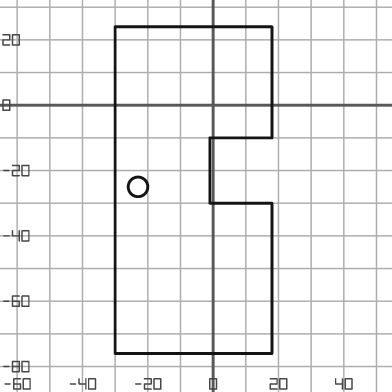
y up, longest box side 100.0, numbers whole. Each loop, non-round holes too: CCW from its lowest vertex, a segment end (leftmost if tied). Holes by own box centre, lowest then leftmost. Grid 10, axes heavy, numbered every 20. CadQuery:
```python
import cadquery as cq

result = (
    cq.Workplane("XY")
    .moveTo(-30.0, -76.0)
    .lineTo(18.0, -76.0)
    .lineTo(18.0, -30.0)
    .lineTo(-1.0, -30.0)
    .lineTo(-1.0, -10.0)
    .lineTo(18.0, -10.0)
    .lineTo(18.0, 24.0)
    .lineTo(-30.0, 24.0)
    .close()
    .moveTo(-23.0, -25.0)
    .circle(3.0)
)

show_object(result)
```